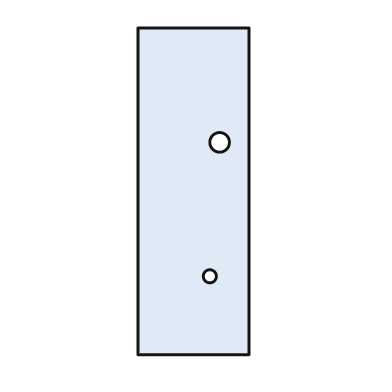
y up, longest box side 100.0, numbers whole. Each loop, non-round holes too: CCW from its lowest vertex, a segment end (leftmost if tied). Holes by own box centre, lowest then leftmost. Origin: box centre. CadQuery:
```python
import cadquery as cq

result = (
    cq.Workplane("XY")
    .moveTo(-17.0, -50.0)
    .lineTo(17.0, -50.0)
    .lineTo(17.0, 50.0)
    .lineTo(-17.0, 50.0)
    .close()
    .moveTo(5.0, -26.0)
    .circle(2.0)
    .moveTo(8.0, 15.0)
    .circle(3.0)
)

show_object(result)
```